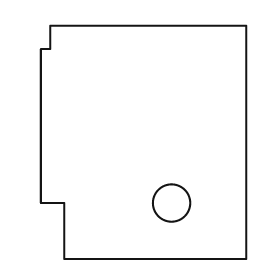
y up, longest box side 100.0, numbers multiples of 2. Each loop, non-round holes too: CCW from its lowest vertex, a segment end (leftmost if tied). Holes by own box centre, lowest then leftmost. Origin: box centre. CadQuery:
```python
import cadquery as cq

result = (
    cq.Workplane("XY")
    .moveTo(-34.0, -50.0)
    .lineTo(44.0, -50.0)
    .lineTo(44.0, 50.0)
    .lineTo(-40.0, 50.0)
    .lineTo(-40.0, 40.0)
    .lineTo(-44.0, 40.0)
    .lineTo(-44.0, -26.0)
    .lineTo(-34.0, -26.0)
    .close()
    .moveTo(12.0, -26.0)
    .circle(8.0)
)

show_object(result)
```